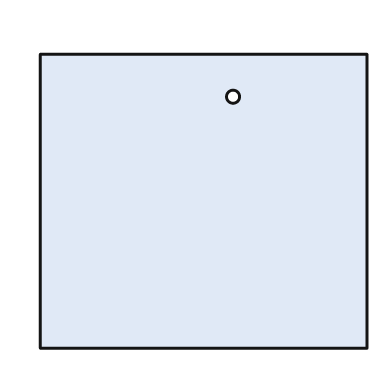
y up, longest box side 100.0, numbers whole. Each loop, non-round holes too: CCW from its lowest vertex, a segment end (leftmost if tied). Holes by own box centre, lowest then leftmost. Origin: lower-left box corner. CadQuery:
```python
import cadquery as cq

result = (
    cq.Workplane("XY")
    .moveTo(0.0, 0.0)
    .lineTo(100.0, 0.0)
    .lineTo(100.0, 90.0)
    .lineTo(0.0, 90.0)
    .close()
    .moveTo(59.0, 77.0)
    .circle(2.0)
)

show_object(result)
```